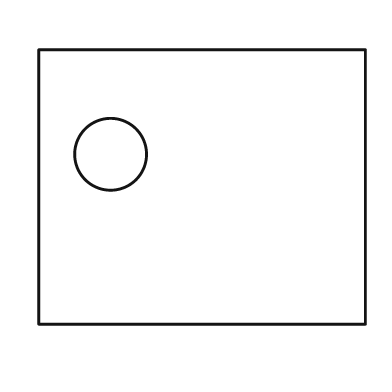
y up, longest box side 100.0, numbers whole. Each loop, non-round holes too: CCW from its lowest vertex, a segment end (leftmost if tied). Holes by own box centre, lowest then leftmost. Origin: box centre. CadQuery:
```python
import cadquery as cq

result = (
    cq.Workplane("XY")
    .moveTo(-50.0, -42.0)
    .lineTo(50.0, -42.0)
    .lineTo(50.0, 42.0)
    .lineTo(-50.0, 42.0)
    .close()
    .moveTo(-28.0, 10.0)
    .circle(11.0)
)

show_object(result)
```